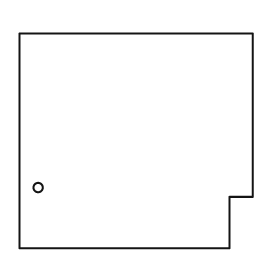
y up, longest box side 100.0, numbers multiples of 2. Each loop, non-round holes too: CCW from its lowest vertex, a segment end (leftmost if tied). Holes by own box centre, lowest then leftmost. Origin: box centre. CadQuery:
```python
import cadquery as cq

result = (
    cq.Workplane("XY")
    .moveTo(-50.0, -46.0)
    .lineTo(40.0, -46.0)
    .lineTo(40.0, -24.0)
    .lineTo(50.0, -24.0)
    .lineTo(50.0, 46.0)
    .lineTo(-50.0, 46.0)
    .close()
    .moveTo(-42.0, -20.0)
    .circle(2.0)
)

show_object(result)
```